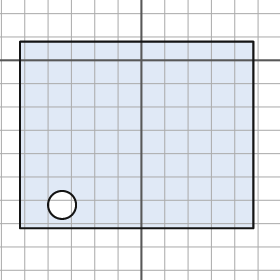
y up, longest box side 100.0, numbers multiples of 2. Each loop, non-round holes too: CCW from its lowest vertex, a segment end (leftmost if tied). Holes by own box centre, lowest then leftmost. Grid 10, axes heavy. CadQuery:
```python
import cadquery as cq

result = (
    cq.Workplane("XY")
    .moveTo(-52.0, -72.0)
    .lineTo(48.0, -72.0)
    .lineTo(48.0, 8.0)
    .lineTo(-52.0, 8.0)
    .close()
    .moveTo(-34.0, -62.0)
    .circle(6.0)
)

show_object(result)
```